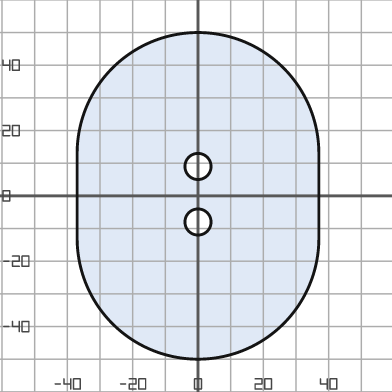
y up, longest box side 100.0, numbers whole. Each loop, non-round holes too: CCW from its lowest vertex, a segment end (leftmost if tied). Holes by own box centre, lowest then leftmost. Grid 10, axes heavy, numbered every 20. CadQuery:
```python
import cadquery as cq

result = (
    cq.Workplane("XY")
    .moveTo(-37.0, -13.0)
    .threePointArc((0.0, -50.0), (37.0, -13.0))
    .lineTo(37.0, 13.0)
    .threePointArc((0.0, 50.0), (-37.0, 13.0))
    .close()
    .moveTo(0.0, -8.0)
    .circle(4.0)
    .moveTo(0.0, 9.0)
    .circle(4.0)
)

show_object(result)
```